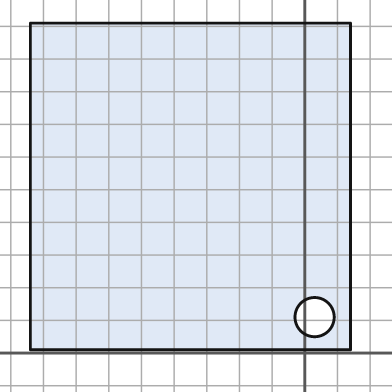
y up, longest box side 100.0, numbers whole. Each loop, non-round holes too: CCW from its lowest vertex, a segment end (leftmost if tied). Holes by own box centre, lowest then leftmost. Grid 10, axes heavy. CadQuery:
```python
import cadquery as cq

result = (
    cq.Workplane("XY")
    .moveTo(-84.0, 1.0)
    .lineTo(14.0, 1.0)
    .lineTo(14.0, 101.0)
    .lineTo(-84.0, 101.0)
    .close()
    .moveTo(3.0, 11.0)
    .circle(6.0)
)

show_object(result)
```